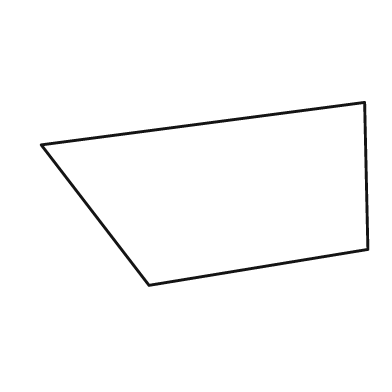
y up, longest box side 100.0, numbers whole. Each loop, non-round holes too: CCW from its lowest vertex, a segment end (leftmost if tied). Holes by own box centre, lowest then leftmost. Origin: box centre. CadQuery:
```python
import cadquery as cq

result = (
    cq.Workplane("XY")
    .moveTo(-17.0, -28.0)
    .lineTo(50.0, -17.0)
    .lineTo(49.0, 28.0)
    .lineTo(-50.0, 15.0)
    .close()
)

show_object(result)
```